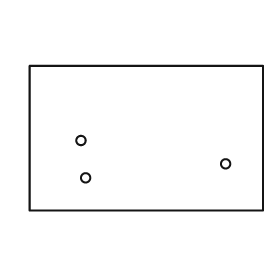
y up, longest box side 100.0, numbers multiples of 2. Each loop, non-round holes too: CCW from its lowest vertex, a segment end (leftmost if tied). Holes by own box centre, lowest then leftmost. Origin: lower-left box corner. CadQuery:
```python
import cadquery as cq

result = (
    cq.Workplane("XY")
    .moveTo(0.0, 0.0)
    .lineTo(100.0, 0.0)
    .lineTo(100.0, 62.0)
    .lineTo(0.0, 62.0)
    .close()
    .moveTo(24.0, 14.0)
    .circle(2.0)
    .moveTo(84.0, 20.0)
    .circle(2.0)
    .moveTo(22.0, 30.0)
    .circle(2.0)
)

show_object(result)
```